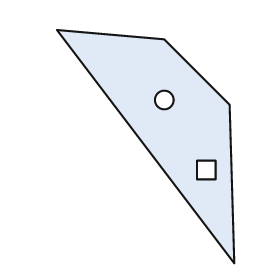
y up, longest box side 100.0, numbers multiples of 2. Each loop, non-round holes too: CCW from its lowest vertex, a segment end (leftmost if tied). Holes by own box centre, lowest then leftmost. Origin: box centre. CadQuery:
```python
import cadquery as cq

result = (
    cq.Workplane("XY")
    .moveTo(38.0, -50.0)
    .lineTo(36.0, 18.0)
    .lineTo(8.0, 46.0)
    .lineTo(-38.0, 50.0)
    .close()
    .moveTo(22.0, -14.0)
    .lineTo(30.0, -14.0)
    .lineTo(30.0, -6.0)
    .lineTo(22.0, -6.0)
    .close()
    .moveTo(8.0, 20.0)
    .circle(4.0)
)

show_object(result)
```